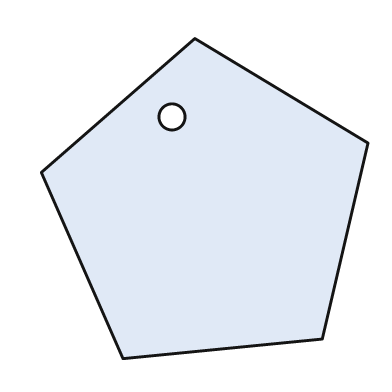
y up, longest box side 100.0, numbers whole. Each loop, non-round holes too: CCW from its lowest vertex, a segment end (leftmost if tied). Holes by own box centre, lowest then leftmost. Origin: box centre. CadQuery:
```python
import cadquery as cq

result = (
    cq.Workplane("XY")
    .moveTo(-25.0, -49.0)
    .lineTo(36.0, -43.0)
    .lineTo(50.0, 17.0)
    .lineTo(-3.0, 49.0)
    .lineTo(-50.0, 8.0)
    .close()
    .moveTo(-10.0, 25.0)
    .circle(4.0)
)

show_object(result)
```